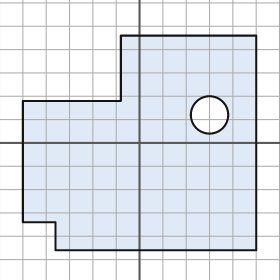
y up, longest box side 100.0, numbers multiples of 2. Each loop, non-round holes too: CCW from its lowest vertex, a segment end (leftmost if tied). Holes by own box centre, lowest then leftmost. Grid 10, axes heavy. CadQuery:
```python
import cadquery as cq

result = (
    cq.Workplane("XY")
    .moveTo(-36.0, -46.0)
    .lineTo(50.0, -46.0)
    .lineTo(50.0, 46.0)
    .lineTo(-8.0, 46.0)
    .lineTo(-8.0, 18.0)
    .lineTo(-50.0, 18.0)
    .lineTo(-50.0, -34.0)
    .lineTo(-36.0, -34.0)
    .close()
    .moveTo(30.0, 12.0)
    .circle(8.0)
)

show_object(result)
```